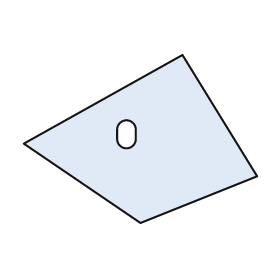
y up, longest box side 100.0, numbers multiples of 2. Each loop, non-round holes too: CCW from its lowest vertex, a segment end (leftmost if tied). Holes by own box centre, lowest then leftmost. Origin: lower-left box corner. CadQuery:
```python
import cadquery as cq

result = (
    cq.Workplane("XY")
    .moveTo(50.0, 0.0)
    .lineTo(100.0, 20.0)
    .lineTo(68.0, 72.0)
    .lineTo(0.0, 34.0)
    .close()
    .moveTo(40.0, 36.0)
    .threePointArc((44.0, 32.0), (48.0, 36.0))
    .lineTo(48.0, 40.0)
    .threePointArc((44.0, 44.0), (40.0, 40.0))
    .close()
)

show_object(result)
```